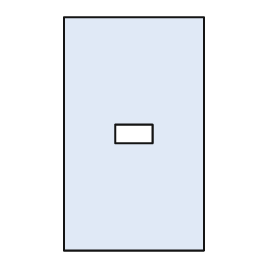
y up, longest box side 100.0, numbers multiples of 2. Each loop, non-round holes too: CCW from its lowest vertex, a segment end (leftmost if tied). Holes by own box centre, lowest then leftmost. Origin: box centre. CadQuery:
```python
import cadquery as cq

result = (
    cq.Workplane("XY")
    .moveTo(-30.0, -50.0)
    .lineTo(30.0, -50.0)
    .lineTo(30.0, 50.0)
    .lineTo(-30.0, 50.0)
    .close()
    .moveTo(-8.0, -4.0)
    .lineTo(8.0, -4.0)
    .lineTo(8.0, 4.0)
    .lineTo(-8.0, 4.0)
    .close()
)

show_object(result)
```